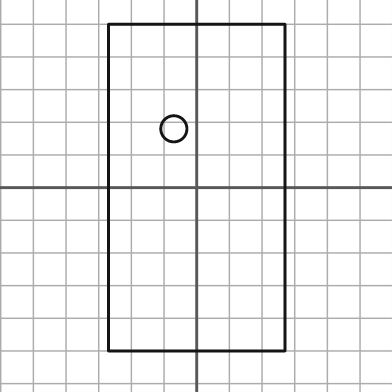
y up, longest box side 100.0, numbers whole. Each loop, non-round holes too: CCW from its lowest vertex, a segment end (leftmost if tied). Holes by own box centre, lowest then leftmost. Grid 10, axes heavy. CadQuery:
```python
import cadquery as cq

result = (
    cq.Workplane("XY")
    .moveTo(-27.0, -50.0)
    .lineTo(27.0, -50.0)
    .lineTo(27.0, 50.0)
    .lineTo(-27.0, 50.0)
    .close()
    .moveTo(-7.0, 18.0)
    .circle(4.0)
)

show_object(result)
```